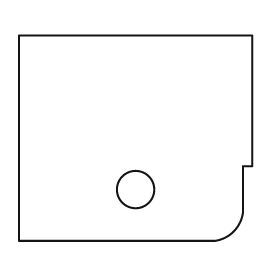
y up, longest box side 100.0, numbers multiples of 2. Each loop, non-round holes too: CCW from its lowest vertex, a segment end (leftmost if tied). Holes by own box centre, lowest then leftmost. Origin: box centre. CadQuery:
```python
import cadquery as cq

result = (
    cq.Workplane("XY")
    .moveTo(-50.0, -44.0)
    .lineTo(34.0, -44.0)
    .threePointArc((42.0, -40.0), (46.0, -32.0))
    .lineTo(46.0, -12.0)
    .lineTo(50.0, -12.0)
    .lineTo(50.0, 44.0)
    .lineTo(-50.0, 44.0)
    .close()
    .moveTo(0.0, -22.0)
    .circle(8.0)
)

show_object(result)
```